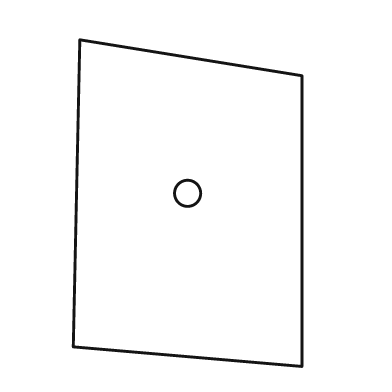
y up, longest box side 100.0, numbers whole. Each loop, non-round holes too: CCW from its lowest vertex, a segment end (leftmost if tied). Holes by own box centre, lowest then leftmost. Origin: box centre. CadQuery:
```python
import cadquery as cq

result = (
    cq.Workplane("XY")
    .moveTo(35.0, -50.0)
    .lineTo(35.0, 39.0)
    .lineTo(-33.0, 50.0)
    .lineTo(-35.0, -44.0)
    .close()
    .moveTo(0.0, 3.0)
    .circle(4.0)
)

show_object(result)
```